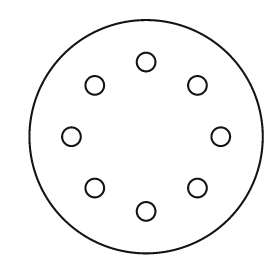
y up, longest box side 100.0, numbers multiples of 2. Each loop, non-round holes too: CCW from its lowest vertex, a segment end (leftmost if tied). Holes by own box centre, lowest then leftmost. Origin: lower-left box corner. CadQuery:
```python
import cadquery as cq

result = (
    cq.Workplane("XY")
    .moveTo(50.0, 50.0)
    .circle(50.0)
    .moveTo(50.0, 18.0)
    .circle(4.0)
    .moveTo(28.0, 28.0)
    .circle(4.0)
    .moveTo(72.0, 28.0)
    .circle(4.0)
    .moveTo(18.0, 50.0)
    .circle(4.0)
    .moveTo(82.0, 50.0)
    .circle(4.0)
    .moveTo(28.0, 72.0)
    .circle(4.0)
    .moveTo(72.0, 72.0)
    .circle(4.0)
    .moveTo(50.0, 82.0)
    .circle(4.0)
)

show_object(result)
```